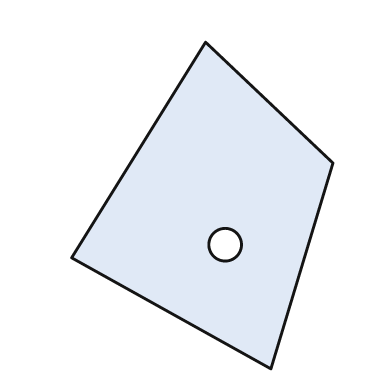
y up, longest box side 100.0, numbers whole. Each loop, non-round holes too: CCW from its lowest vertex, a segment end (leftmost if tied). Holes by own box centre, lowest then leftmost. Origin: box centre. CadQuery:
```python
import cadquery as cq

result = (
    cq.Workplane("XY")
    .moveTo(21.0, -50.0)
    .lineTo(40.0, 13.0)
    .lineTo(1.0, 50.0)
    .lineTo(-40.0, -16.0)
    .close()
    .moveTo(7.0, -12.0)
    .circle(5.0)
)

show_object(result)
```